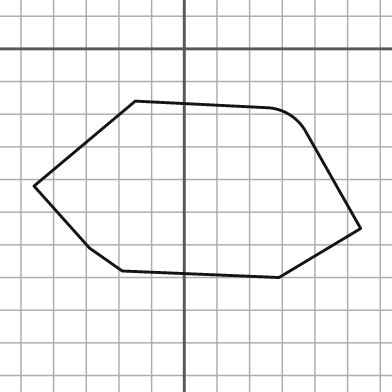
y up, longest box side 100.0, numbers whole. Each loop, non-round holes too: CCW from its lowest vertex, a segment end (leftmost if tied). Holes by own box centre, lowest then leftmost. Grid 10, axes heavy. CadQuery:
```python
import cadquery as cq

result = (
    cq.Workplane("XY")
    .moveTo(29.0, -70.0)
    .lineTo(54.0, -55.0)
    .lineTo(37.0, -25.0)
    .threePointArc((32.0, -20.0), (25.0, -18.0))
    .lineTo(-15.0, -16.0)
    .lineTo(-46.0, -42.0)
    .lineTo(-29.0, -61.0)
    .lineTo(-19.0, -68.0)
    .close()
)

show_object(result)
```